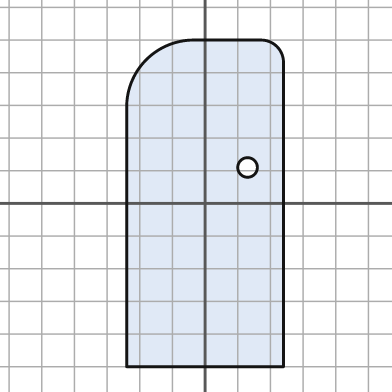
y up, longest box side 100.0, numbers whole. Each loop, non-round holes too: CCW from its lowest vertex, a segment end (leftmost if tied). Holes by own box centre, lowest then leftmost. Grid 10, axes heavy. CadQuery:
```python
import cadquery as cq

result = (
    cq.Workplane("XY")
    .moveTo(-24.0, -50.0)
    .lineTo(24.0, -50.0)
    .lineTo(24.0, 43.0)
    .threePointArc((22.0, 48.0), (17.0, 50.0))
    .lineTo(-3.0, 50.0)
    .threePointArc((-18.0, 44.0), (-24.0, 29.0))
    .close()
    .moveTo(13.0, 11.0)
    .circle(3.0)
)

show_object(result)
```